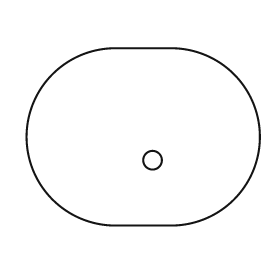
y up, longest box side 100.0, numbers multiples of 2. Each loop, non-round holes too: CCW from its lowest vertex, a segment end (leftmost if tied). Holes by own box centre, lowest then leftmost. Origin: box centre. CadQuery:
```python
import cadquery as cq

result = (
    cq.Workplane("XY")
    .moveTo(-12.0, -38.0)
    .lineTo(12.0, -38.0)
    .threePointArc((50.0, 0.0), (12.0, 38.0))
    .lineTo(-12.0, 38.0)
    .threePointArc((-50.0, 0.0), (-12.0, -38.0))
    .close()
    .moveTo(4.0, -10.0)
    .circle(4.0)
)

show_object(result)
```